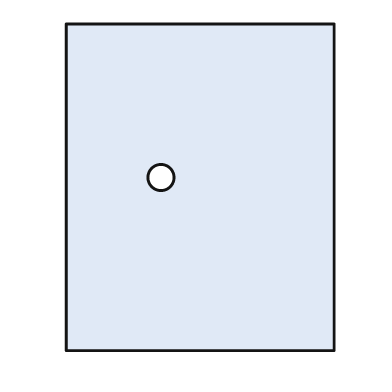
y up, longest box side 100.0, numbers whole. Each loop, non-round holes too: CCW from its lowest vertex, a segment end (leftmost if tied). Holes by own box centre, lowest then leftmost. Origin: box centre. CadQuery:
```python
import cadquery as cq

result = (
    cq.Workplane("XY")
    .moveTo(-41.0, -50.0)
    .lineTo(41.0, -50.0)
    .lineTo(41.0, 50.0)
    .lineTo(-41.0, 50.0)
    .close()
    .moveTo(-12.0, 3.0)
    .circle(4.0)
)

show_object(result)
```